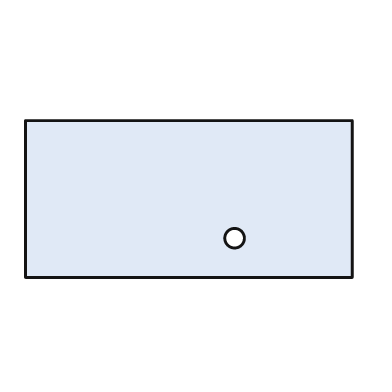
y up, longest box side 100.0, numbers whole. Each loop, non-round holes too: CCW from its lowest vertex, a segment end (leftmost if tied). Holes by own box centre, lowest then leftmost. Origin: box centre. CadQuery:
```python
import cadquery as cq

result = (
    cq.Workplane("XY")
    .moveTo(-50.0, -24.0)
    .lineTo(50.0, -24.0)
    .lineTo(50.0, 24.0)
    .lineTo(-50.0, 24.0)
    .close()
    .moveTo(14.0, -12.0)
    .circle(3.0)
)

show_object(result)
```